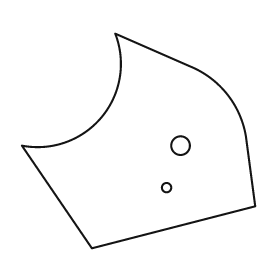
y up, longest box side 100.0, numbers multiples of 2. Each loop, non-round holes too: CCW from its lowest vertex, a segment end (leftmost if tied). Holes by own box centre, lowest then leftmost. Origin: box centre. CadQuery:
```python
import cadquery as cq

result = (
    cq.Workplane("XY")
    .moveTo(-20.0, -46.0)
    .lineTo(50.0, -28.0)
    .lineTo(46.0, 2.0)
    .threePointArc((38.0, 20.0), (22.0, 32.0))
    .lineTo(-10.0, 46.0)
    .threePointArc((-16.0, 10.0), (-50.0, -2.0))
    .close()
    .moveTo(12.0, -20.0)
    .circle(2.0)
    .moveTo(18.0, -2.0)
    .circle(4.0)
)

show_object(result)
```